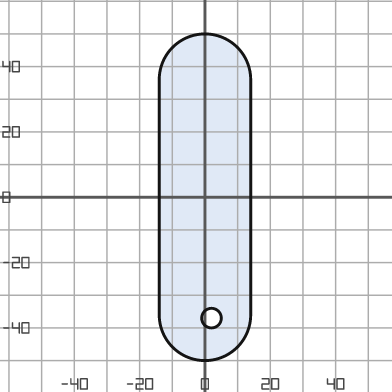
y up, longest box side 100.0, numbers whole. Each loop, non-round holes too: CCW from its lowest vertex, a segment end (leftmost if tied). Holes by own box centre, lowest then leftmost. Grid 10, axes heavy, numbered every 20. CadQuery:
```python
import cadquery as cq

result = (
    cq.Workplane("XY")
    .moveTo(-14.0, -36.0)
    .threePointArc((0.0, -50.0), (14.0, -36.0))
    .lineTo(14.0, 36.0)
    .threePointArc((0.0, 50.0), (-14.0, 36.0))
    .close()
    .moveTo(2.0, -37.0)
    .circle(3.0)
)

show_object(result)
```